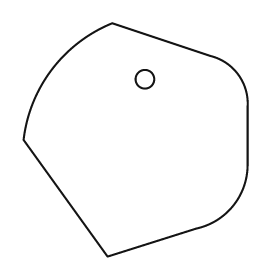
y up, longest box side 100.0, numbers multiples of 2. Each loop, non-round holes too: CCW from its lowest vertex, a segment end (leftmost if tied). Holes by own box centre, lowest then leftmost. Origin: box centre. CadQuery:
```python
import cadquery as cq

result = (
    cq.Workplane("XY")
    .moveTo(-12.0, -50.0)
    .lineTo(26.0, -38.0)
    .threePointArc((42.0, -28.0), (48.0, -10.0))
    .lineTo(48.0, 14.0)
    .threePointArc((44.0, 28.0), (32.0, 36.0))
    .lineTo(-10.0, 50.0)
    .threePointArc((-36.0, 30.0), (-48.0, 0.0))
    .close()
    .moveTo(4.0, 26.0)
    .circle(4.0)
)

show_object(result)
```